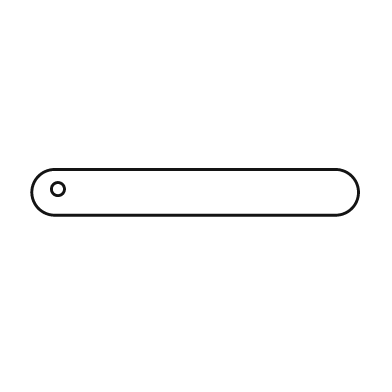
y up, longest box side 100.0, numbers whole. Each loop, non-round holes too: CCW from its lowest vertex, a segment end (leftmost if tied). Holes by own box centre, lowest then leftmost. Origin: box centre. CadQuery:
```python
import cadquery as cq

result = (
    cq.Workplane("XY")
    .moveTo(-43.0, -7.0)
    .lineTo(43.0, -7.0)
    .threePointArc((50.0, 0.0), (43.0, 7.0))
    .lineTo(-43.0, 7.0)
    .threePointArc((-50.0, 0.0), (-43.0, -7.0))
    .close()
    .moveTo(-42.0, 1.0)
    .circle(2.0)
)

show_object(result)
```